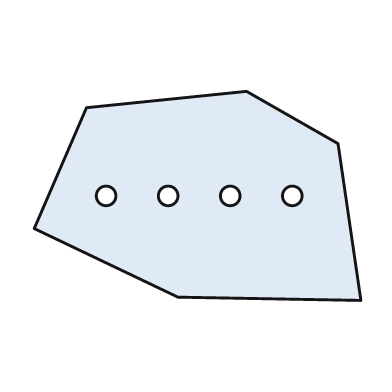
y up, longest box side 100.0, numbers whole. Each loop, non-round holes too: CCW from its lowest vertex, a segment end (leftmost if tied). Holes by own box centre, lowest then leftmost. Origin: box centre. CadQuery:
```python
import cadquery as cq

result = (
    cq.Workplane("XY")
    .moveTo(50.0, -32.0)
    .lineTo(43.0, 16.0)
    .lineTo(15.0, 32.0)
    .lineTo(-34.0, 27.0)
    .lineTo(-50.0, -10.0)
    .lineTo(-6.0, -31.0)
    .close()
    .moveTo(-28.0, 0.0)
    .circle(3.0)
    .moveTo(-9.0, 0.0)
    .circle(3.0)
    .moveTo(10.0, 0.0)
    .circle(3.0)
    .moveTo(29.0, 0.0)
    .circle(3.0)
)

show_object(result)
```